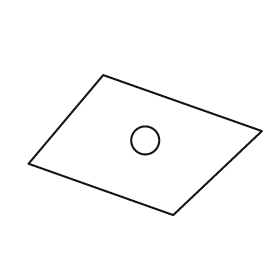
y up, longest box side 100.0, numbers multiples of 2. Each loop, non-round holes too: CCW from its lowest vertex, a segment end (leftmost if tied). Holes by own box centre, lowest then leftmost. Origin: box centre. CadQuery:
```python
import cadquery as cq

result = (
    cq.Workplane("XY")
    .moveTo(12.0, -30.0)
    .lineTo(50.0, 6.0)
    .lineTo(-18.0, 30.0)
    .lineTo(-50.0, -8.0)
    .close()
    .moveTo(0.0, 2.0)
    .circle(6.0)
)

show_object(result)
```